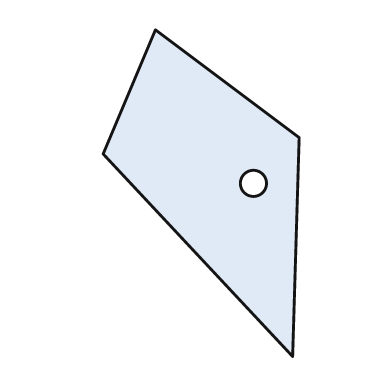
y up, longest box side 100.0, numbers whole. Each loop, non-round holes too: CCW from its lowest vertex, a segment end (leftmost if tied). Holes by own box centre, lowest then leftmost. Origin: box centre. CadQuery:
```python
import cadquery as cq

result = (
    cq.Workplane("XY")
    .moveTo(28.0, -50.0)
    .lineTo(30.0, 17.0)
    .lineTo(-14.0, 50.0)
    .lineTo(-30.0, 12.0)
    .close()
    .moveTo(16.0, 3.0)
    .circle(4.0)
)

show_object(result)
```